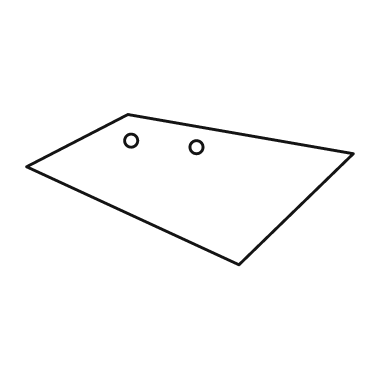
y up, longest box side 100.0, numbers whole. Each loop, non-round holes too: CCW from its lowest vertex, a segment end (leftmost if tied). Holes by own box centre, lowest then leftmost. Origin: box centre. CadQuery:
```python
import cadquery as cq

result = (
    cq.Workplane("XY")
    .moveTo(15.0, -23.0)
    .lineTo(50.0, 11.0)
    .lineTo(-19.0, 23.0)
    .lineTo(-50.0, 7.0)
    .close()
    .moveTo(2.0, 13.0)
    .circle(2.0)
    .moveTo(-18.0, 15.0)
    .circle(2.0)
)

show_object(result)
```